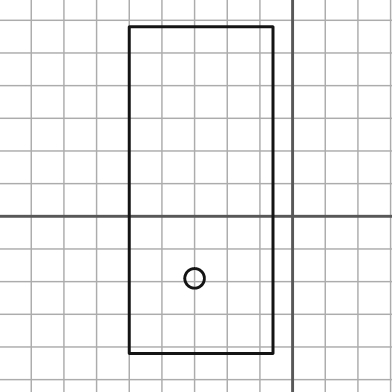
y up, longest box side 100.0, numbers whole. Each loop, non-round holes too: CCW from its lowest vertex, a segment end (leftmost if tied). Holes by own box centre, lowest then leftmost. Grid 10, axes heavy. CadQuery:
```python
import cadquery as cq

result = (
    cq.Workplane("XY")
    .moveTo(-50.0, -42.0)
    .lineTo(-6.0, -42.0)
    .lineTo(-6.0, 58.0)
    .lineTo(-50.0, 58.0)
    .close()
    .moveTo(-30.0, -19.0)
    .circle(3.0)
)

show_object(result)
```